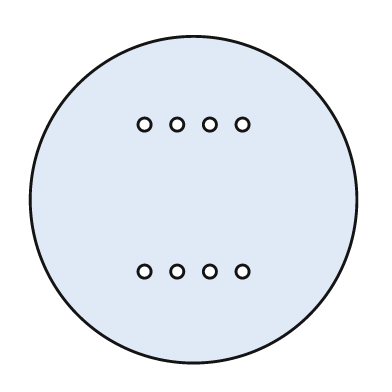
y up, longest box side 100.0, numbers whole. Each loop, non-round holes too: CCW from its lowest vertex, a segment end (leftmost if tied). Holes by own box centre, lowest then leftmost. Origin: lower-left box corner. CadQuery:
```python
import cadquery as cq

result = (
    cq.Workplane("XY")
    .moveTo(50.0, 50.0)
    .circle(50.0)
    .moveTo(35.0, 28.0)
    .circle(2.0)
    .moveTo(45.0, 28.0)
    .circle(2.0)
    .moveTo(55.0, 28.0)
    .circle(2.0)
    .moveTo(65.0, 28.0)
    .circle(2.0)
    .moveTo(35.0, 73.0)
    .circle(2.0)
    .moveTo(45.0, 73.0)
    .circle(2.0)
    .moveTo(55.0, 73.0)
    .circle(2.0)
    .moveTo(65.0, 73.0)
    .circle(2.0)
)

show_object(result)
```